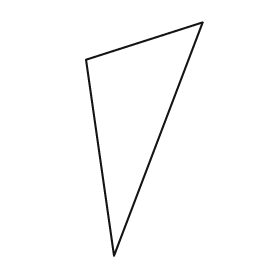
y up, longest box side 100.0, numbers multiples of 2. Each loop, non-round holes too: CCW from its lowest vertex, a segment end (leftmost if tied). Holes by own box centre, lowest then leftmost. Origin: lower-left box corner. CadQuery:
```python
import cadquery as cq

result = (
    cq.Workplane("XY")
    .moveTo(12.0, 0.0)
    .lineTo(50.0, 100.0)
    .lineTo(0.0, 84.0)
    .close()
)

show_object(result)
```